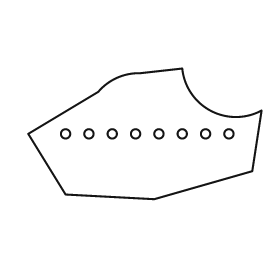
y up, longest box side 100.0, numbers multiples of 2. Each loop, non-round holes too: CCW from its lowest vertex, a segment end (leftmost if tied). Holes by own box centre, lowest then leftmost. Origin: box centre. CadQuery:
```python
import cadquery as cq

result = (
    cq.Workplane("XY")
    .moveTo(4.0, -28.0)
    .lineTo(46.0, -16.0)
    .lineTo(50.0, 10.0)
    .threePointArc((28.0, 10.0), (16.0, 28.0))
    .lineTo(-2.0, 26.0)
    .threePointArc((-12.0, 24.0), (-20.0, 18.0))
    .lineTo(-50.0, 0.0)
    .lineTo(-34.0, -26.0)
    .close()
    .moveTo(-34.0, 0.0)
    .circle(2.0)
    .moveTo(-24.0, 0.0)
    .circle(2.0)
    .moveTo(-14.0, 0.0)
    .circle(2.0)
    .moveTo(-4.0, 0.0)
    .circle(2.0)
    .moveTo(6.0, 0.0)
    .circle(2.0)
    .moveTo(16.0, 0.0)
    .circle(2.0)
    .moveTo(26.0, 0.0)
    .circle(2.0)
    .moveTo(36.0, 0.0)
    .circle(2.0)
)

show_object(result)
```